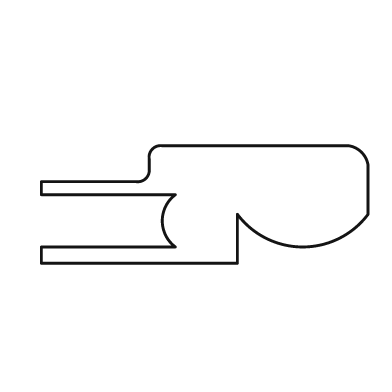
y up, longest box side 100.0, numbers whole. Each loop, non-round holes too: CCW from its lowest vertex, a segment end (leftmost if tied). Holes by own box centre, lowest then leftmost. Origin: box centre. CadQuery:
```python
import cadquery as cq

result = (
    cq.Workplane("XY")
    .moveTo(-50.0, -18.0)
    .lineTo(10.0, -18.0)
    .lineTo(10.0, -3.0)
    .threePointArc((30.0, -13.0), (50.0, -3.0))
    .lineTo(50.0, 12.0)
    .threePointArc((48.0, 16.0), (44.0, 18.0))
    .lineTo(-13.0, 18.0)
    .threePointArc((-16.0, 17.0), (-17.0, 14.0))
    .lineTo(-17.0, 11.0)
    .threePointArc((-18.0, 8.0), (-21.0, 7.0))
    .lineTo(-50.0, 7.0)
    .lineTo(-50.0, 3.0)
    .lineTo(-9.0, 3.0)
    .threePointArc((-13.0, -5.0), (-9.0, -13.0))
    .lineTo(-50.0, -13.0)
    .close()
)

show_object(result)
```